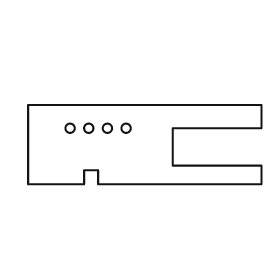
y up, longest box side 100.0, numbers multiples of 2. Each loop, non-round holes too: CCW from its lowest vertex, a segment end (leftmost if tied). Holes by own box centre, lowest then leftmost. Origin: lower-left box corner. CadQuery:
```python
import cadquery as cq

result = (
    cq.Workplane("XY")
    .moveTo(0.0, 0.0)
    .lineTo(24.0, 0.0)
    .lineTo(24.0, 6.0)
    .lineTo(30.0, 6.0)
    .lineTo(30.0, 0.0)
    .lineTo(100.0, 0.0)
    .lineTo(100.0, 8.0)
    .lineTo(62.0, 8.0)
    .lineTo(62.0, 24.0)
    .lineTo(100.0, 24.0)
    .lineTo(100.0, 34.0)
    .lineTo(0.0, 34.0)
    .close()
    .moveTo(18.0, 24.0)
    .circle(2.0)
    .moveTo(26.0, 24.0)
    .circle(2.0)
    .moveTo(34.0, 24.0)
    .circle(2.0)
    .moveTo(42.0, 24.0)
    .circle(2.0)
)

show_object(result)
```